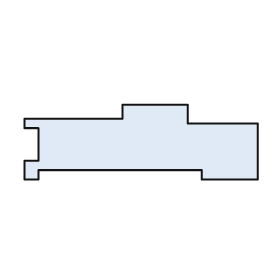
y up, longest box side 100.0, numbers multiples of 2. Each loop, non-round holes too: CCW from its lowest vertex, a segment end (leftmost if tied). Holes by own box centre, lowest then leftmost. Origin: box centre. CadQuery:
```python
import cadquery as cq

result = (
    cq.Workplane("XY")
    .moveTo(-50.0, -16.0)
    .lineTo(-44.0, -16.0)
    .lineTo(-44.0, -12.0)
    .lineTo(26.0, -12.0)
    .lineTo(26.0, -16.0)
    .lineTo(50.0, -16.0)
    .lineTo(50.0, 8.0)
    .lineTo(20.0, 8.0)
    .lineTo(20.0, 16.0)
    .lineTo(-8.0, 16.0)
    .lineTo(-8.0, 10.0)
    .lineTo(-50.0, 10.0)
    .lineTo(-50.0, 6.0)
    .lineTo(-44.0, 6.0)
    .lineTo(-44.0, -8.0)
    .lineTo(-50.0, -8.0)
    .close()
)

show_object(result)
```